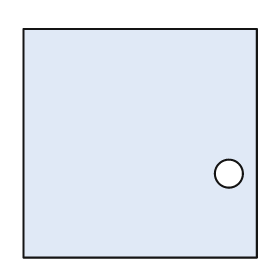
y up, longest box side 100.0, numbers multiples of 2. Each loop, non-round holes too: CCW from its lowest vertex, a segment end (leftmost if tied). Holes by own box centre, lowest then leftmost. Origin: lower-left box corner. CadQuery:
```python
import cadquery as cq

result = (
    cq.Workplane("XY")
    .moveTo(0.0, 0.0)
    .lineTo(100.0, 0.0)
    .lineTo(100.0, 98.0)
    .lineTo(0.0, 98.0)
    .close()
    .moveTo(88.0, 36.0)
    .circle(6.0)
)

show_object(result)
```